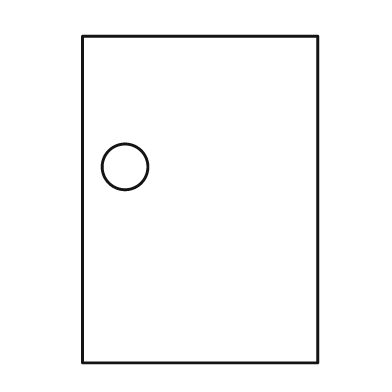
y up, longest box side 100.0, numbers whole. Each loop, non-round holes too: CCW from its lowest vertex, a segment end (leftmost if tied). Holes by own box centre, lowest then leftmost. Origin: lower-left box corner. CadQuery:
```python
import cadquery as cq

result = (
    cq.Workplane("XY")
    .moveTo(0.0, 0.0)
    .lineTo(72.0, 0.0)
    .lineTo(72.0, 100.0)
    .lineTo(0.0, 100.0)
    .close()
    .moveTo(13.0, 60.0)
    .circle(7.0)
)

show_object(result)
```